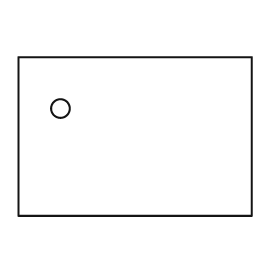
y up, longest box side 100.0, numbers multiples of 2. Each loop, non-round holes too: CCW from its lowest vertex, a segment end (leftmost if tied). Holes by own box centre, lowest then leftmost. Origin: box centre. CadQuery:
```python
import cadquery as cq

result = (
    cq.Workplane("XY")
    .moveTo(-50.0, -34.0)
    .lineTo(50.0, -34.0)
    .lineTo(50.0, 34.0)
    .lineTo(-50.0, 34.0)
    .close()
    .moveTo(-32.0, 12.0)
    .circle(4.0)
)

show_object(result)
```